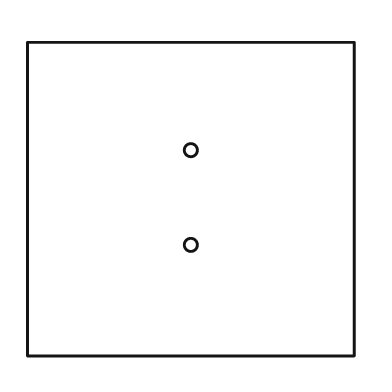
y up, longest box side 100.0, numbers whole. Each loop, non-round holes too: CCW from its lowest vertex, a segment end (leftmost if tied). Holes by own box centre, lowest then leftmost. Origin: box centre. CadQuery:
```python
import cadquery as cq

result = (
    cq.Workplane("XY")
    .moveTo(-50.0, -48.0)
    .lineTo(50.0, -48.0)
    .lineTo(50.0, 48.0)
    .lineTo(-50.0, 48.0)
    .close()
    .moveTo(0.0, -14.0)
    .circle(2.0)
    .moveTo(0.0, 15.0)
    .circle(2.0)
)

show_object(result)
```